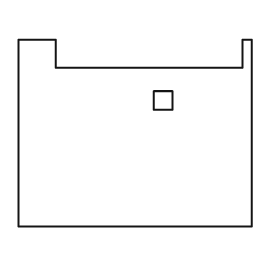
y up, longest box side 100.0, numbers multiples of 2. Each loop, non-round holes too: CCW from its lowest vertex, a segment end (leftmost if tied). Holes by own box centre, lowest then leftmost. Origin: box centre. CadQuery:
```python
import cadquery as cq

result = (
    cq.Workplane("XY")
    .moveTo(-50.0, -40.0)
    .lineTo(50.0, -40.0)
    .lineTo(50.0, 40.0)
    .lineTo(46.0, 40.0)
    .lineTo(46.0, 28.0)
    .lineTo(-34.0, 28.0)
    .lineTo(-34.0, 40.0)
    .lineTo(-50.0, 40.0)
    .close()
    .moveTo(8.0, 10.0)
    .lineTo(16.0, 10.0)
    .lineTo(16.0, 18.0)
    .lineTo(8.0, 18.0)
    .close()
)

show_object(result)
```